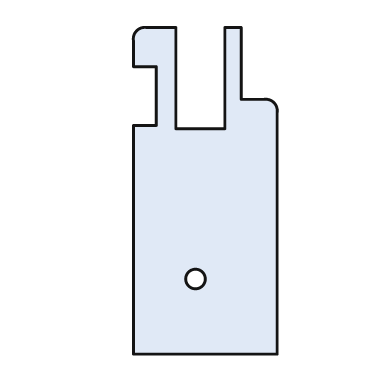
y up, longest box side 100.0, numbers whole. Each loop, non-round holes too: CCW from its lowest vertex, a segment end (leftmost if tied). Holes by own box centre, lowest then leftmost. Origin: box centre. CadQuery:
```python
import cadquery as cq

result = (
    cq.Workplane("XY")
    .moveTo(-22.0, -50.0)
    .lineTo(22.0, -50.0)
    .lineTo(22.0, 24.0)
    .threePointArc((21.0, 27.0), (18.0, 28.0))
    .lineTo(11.0, 28.0)
    .lineTo(11.0, 50.0)
    .lineTo(6.0, 50.0)
    .lineTo(6.0, 19.0)
    .lineTo(-9.0, 19.0)
    .lineTo(-9.0, 50.0)
    .lineTo(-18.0, 50.0)
    .threePointArc((-21.0, 49.0), (-22.0, 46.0))
    .lineTo(-22.0, 38.0)
    .lineTo(-15.0, 38.0)
    .lineTo(-15.0, 20.0)
    .lineTo(-22.0, 20.0)
    .close()
    .moveTo(-3.0, -27.0)
    .circle(3.0)
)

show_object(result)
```